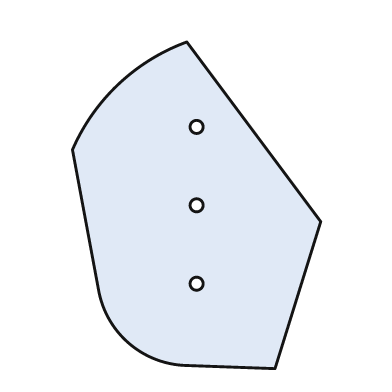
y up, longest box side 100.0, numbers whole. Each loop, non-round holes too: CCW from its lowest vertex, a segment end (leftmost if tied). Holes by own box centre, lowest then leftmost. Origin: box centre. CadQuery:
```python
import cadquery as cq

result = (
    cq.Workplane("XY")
    .moveTo(24.0, -50.0)
    .lineTo(38.0, -5.0)
    .lineTo(-3.0, 50.0)
    .threePointArc((-24.0, 37.0), (-38.0, 17.0))
    .lineTo(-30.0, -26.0)
    .threePointArc((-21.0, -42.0), (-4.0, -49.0))
    .close()
    .moveTo(0.0, -24.0)
    .circle(2.0)
    .moveTo(0.0, 0.0)
    .circle(2.0)
    .moveTo(0.0, 24.0)
    .circle(2.0)
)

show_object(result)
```